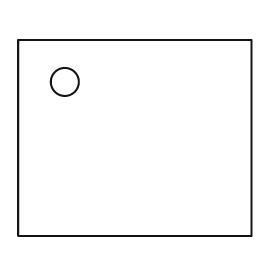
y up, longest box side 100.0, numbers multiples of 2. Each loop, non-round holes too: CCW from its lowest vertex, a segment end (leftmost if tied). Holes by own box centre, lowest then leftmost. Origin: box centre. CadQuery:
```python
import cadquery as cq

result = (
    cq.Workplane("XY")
    .moveTo(-50.0, -42.0)
    .lineTo(50.0, -42.0)
    .lineTo(50.0, 42.0)
    .lineTo(-50.0, 42.0)
    .close()
    .moveTo(-30.0, 24.0)
    .circle(6.0)
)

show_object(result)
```